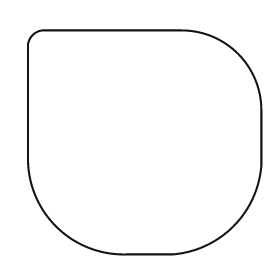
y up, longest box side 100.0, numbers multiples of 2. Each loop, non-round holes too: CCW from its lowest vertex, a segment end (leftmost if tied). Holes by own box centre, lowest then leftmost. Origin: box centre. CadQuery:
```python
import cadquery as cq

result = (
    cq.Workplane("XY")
    .moveTo(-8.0, -48.0)
    .lineTo(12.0, -48.0)
    .threePointArc((38.0, -36.0), (50.0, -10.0))
    .lineTo(50.0, 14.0)
    .threePointArc((40.0, 38.0), (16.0, 48.0))
    .lineTo(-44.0, 48.0)
    .threePointArc((-48.0, 46.0), (-50.0, 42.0))
    .lineTo(-50.0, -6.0)
    .threePointArc((-38.0, -36.0), (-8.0, -48.0))
    .close()
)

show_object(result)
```